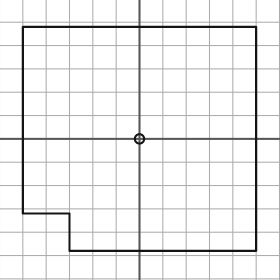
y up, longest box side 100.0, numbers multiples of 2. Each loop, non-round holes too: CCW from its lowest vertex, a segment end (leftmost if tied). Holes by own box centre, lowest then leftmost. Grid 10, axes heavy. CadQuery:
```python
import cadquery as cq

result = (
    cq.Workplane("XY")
    .moveTo(-30.0, -48.0)
    .lineTo(50.0, -48.0)
    .lineTo(50.0, 48.0)
    .lineTo(-50.0, 48.0)
    .lineTo(-50.0, -32.0)
    .lineTo(-30.0, -32.0)
    .close()
    .moveTo(0.0, 0.0)
    .circle(2.0)
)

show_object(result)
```